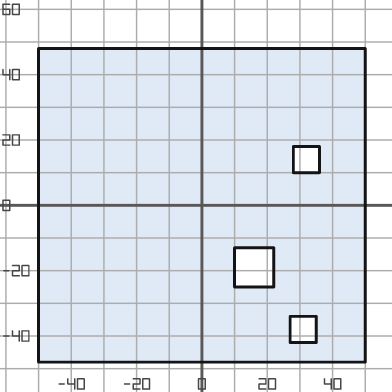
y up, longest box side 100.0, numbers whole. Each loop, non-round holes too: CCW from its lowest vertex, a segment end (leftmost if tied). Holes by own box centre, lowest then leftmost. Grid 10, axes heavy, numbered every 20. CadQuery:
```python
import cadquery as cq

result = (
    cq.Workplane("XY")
    .moveTo(-50.0, -48.0)
    .lineTo(50.0, -48.0)
    .lineTo(50.0, 48.0)
    .lineTo(-50.0, 48.0)
    .close()
    .moveTo(27.0, -42.0)
    .lineTo(35.0, -42.0)
    .lineTo(35.0, -34.0)
    .lineTo(27.0, -34.0)
    .close()
    .moveTo(10.0, -25.0)
    .lineTo(22.0, -25.0)
    .lineTo(22.0, -13.0)
    .lineTo(10.0, -13.0)
    .close()
    .moveTo(28.0, 10.0)
    .lineTo(36.0, 10.0)
    .lineTo(36.0, 18.0)
    .lineTo(28.0, 18.0)
    .close()
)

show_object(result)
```